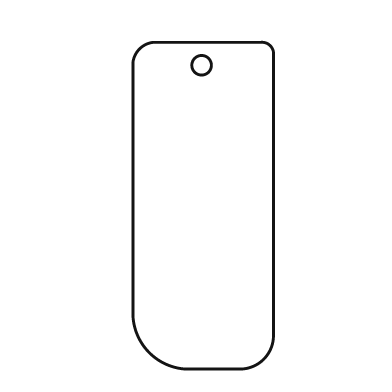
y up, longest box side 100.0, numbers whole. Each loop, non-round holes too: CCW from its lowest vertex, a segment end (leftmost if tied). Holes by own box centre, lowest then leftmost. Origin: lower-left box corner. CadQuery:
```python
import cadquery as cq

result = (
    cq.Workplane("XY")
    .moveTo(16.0, 0.0)
    .lineTo(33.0, 0.0)
    .threePointArc((40.0, 3.0), (43.0, 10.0))
    .lineTo(43.0, 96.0)
    .threePointArc((42.0, 99.0), (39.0, 100.0))
    .lineTo(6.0, 100.0)
    .threePointArc((2.0, 98.0), (0.0, 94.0))
    .lineTo(0.0, 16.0)
    .threePointArc((5.0, 5.0), (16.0, 0.0))
    .close()
    .moveTo(21.0, 93.0)
    .circle(3.0)
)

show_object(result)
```